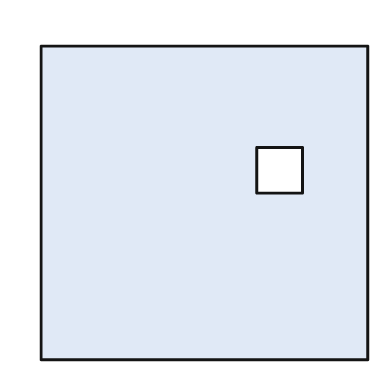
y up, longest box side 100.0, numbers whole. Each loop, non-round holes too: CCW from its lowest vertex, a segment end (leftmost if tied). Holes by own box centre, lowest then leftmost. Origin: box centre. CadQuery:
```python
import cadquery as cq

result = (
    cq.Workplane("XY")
    .moveTo(-50.0, -48.0)
    .lineTo(50.0, -48.0)
    .lineTo(50.0, 48.0)
    .lineTo(-50.0, 48.0)
    .close()
    .moveTo(16.0, 3.0)
    .lineTo(30.0, 3.0)
    .lineTo(30.0, 17.0)
    .lineTo(16.0, 17.0)
    .close()
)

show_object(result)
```